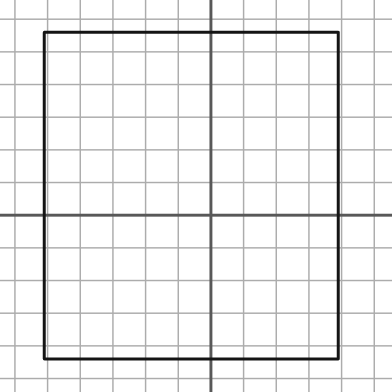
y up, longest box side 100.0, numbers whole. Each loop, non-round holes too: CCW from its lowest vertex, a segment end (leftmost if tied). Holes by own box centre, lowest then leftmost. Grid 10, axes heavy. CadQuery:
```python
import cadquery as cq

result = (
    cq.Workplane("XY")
    .moveTo(-51.0, -44.0)
    .lineTo(39.0, -44.0)
    .lineTo(39.0, 56.0)
    .lineTo(-51.0, 56.0)
    .close()
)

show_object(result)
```